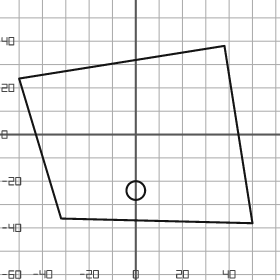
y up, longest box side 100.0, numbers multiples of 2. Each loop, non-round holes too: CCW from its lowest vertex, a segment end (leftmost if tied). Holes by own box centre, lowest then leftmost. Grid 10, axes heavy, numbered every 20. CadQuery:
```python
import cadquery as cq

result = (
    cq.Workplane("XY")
    .moveTo(50.0, -38.0)
    .lineTo(38.0, 38.0)
    .lineTo(-50.0, 24.0)
    .lineTo(-32.0, -36.0)
    .close()
    .moveTo(0.0, -24.0)
    .circle(4.0)
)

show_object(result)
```